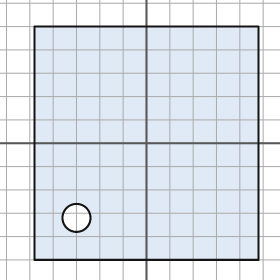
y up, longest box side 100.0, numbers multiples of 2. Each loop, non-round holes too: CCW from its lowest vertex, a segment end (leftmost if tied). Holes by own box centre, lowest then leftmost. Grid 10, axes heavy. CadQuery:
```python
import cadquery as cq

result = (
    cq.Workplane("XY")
    .moveTo(-48.0, -50.0)
    .lineTo(48.0, -50.0)
    .lineTo(48.0, 50.0)
    .lineTo(-48.0, 50.0)
    .close()
    .moveTo(-30.0, -32.0)
    .circle(6.0)
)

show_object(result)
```